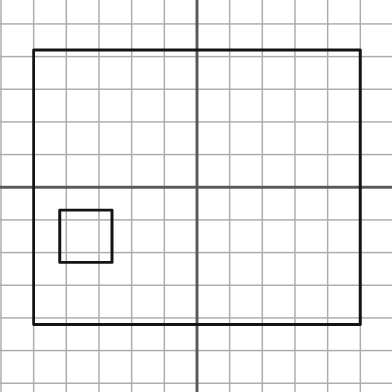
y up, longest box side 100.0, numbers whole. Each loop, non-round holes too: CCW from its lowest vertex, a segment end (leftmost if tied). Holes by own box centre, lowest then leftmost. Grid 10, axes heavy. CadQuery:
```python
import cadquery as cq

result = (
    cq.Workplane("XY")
    .moveTo(-50.0, -42.0)
    .lineTo(50.0, -42.0)
    .lineTo(50.0, 42.0)
    .lineTo(-50.0, 42.0)
    .close()
    .moveTo(-42.0, -23.0)
    .lineTo(-26.0, -23.0)
    .lineTo(-26.0, -7.0)
    .lineTo(-42.0, -7.0)
    .close()
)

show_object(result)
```